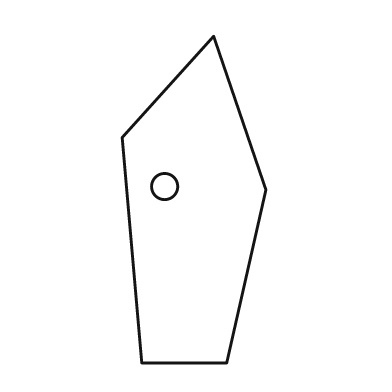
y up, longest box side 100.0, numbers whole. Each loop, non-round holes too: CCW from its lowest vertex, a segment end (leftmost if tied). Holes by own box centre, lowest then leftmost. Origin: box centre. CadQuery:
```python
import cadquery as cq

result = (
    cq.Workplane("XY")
    .moveTo(-16.0, -50.0)
    .lineTo(10.0, -50.0)
    .lineTo(22.0, 3.0)
    .lineTo(6.0, 50.0)
    .lineTo(-22.0, 19.0)
    .close()
    .moveTo(-9.0, 4.0)
    .circle(4.0)
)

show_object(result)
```